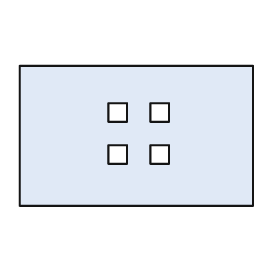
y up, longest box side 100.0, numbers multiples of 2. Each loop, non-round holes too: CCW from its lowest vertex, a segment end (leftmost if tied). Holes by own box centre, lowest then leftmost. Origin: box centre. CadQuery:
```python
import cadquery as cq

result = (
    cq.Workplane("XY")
    .moveTo(-50.0, -30.0)
    .lineTo(50.0, -30.0)
    .lineTo(50.0, 30.0)
    .lineTo(-50.0, 30.0)
    .close()
    .moveTo(-12.0, -12.0)
    .lineTo(-4.0, -12.0)
    .lineTo(-4.0, -4.0)
    .lineTo(-12.0, -4.0)
    .close()
    .moveTo(6.0, -12.0)
    .lineTo(14.0, -12.0)
    .lineTo(14.0, -4.0)
    .lineTo(6.0, -4.0)
    .close()
    .moveTo(-12.0, 6.0)
    .lineTo(-4.0, 6.0)
    .lineTo(-4.0, 14.0)
    .lineTo(-12.0, 14.0)
    .close()
    .moveTo(6.0, 6.0)
    .lineTo(14.0, 6.0)
    .lineTo(14.0, 14.0)
    .lineTo(6.0, 14.0)
    .close()
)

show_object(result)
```